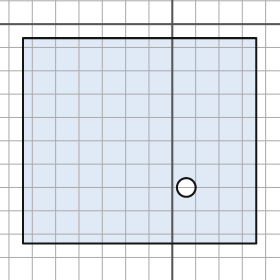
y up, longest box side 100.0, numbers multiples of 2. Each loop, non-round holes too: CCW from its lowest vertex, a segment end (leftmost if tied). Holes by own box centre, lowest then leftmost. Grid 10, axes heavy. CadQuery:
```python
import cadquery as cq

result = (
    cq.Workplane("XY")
    .moveTo(-64.0, -94.0)
    .lineTo(36.0, -94.0)
    .lineTo(36.0, -6.0)
    .lineTo(-64.0, -6.0)
    .close()
    .moveTo(6.0, -70.0)
    .circle(4.0)
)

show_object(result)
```